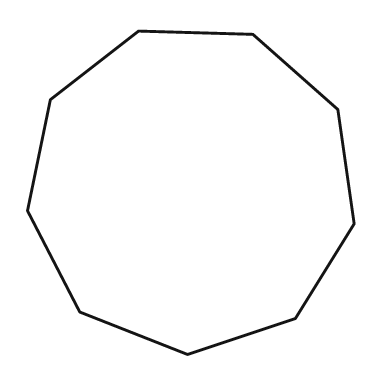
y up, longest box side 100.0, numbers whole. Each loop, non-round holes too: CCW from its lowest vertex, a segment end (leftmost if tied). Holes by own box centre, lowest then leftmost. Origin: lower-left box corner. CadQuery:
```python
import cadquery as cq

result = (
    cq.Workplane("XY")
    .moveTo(49.0, 0.0)
    .lineTo(82.0, 11.0)
    .lineTo(100.0, 40.0)
    .lineTo(95.0, 75.0)
    .lineTo(69.0, 98.0)
    .lineTo(34.0, 99.0)
    .lineTo(7.0, 78.0)
    .lineTo(0.0, 44.0)
    .lineTo(16.0, 13.0)
    .close()
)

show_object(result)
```